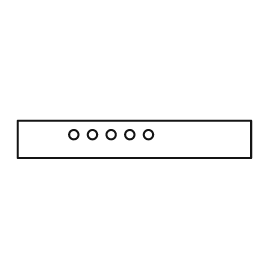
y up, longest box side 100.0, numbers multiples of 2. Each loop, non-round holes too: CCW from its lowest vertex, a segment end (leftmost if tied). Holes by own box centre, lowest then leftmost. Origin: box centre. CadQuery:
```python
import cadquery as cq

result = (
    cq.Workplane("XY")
    .moveTo(-50.0, -8.0)
    .lineTo(50.0, -8.0)
    .lineTo(50.0, 8.0)
    .lineTo(-50.0, 8.0)
    .close()
    .moveTo(-26.0, 2.0)
    .circle(2.0)
    .moveTo(-18.0, 2.0)
    .circle(2.0)
    .moveTo(-10.0, 2.0)
    .circle(2.0)
    .moveTo(-2.0, 2.0)
    .circle(2.0)
    .moveTo(6.0, 2.0)
    .circle(2.0)
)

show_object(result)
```